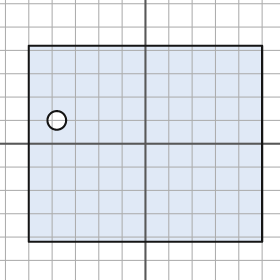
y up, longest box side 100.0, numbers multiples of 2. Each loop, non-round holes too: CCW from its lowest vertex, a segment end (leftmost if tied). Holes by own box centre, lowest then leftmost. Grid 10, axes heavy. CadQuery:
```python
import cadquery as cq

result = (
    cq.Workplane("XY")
    .moveTo(-50.0, -42.0)
    .lineTo(50.0, -42.0)
    .lineTo(50.0, 42.0)
    .lineTo(-50.0, 42.0)
    .close()
    .moveTo(-38.0, 10.0)
    .circle(4.0)
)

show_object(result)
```